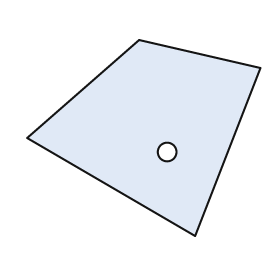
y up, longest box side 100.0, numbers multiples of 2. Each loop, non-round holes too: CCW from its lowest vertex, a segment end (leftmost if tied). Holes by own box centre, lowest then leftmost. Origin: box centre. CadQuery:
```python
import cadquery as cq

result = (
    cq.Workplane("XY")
    .moveTo(22.0, -42.0)
    .lineTo(50.0, 30.0)
    .lineTo(-2.0, 42.0)
    .lineTo(-50.0, 0.0)
    .close()
    .moveTo(10.0, -6.0)
    .circle(4.0)
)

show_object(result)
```